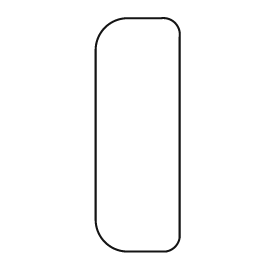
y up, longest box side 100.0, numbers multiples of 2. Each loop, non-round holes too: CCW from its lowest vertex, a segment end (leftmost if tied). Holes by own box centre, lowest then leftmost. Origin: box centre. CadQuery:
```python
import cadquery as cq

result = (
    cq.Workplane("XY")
    .moveTo(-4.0, -50.0)
    .lineTo(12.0, -50.0)
    .threePointArc((16.0, -48.0), (18.0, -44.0))
    .lineTo(18.0, 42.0)
    .threePointArc((16.0, 48.0), (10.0, 50.0))
    .lineTo(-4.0, 50.0)
    .threePointArc((-14.0, 46.0), (-18.0, 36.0))
    .lineTo(-18.0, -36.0)
    .threePointArc((-14.0, -46.0), (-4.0, -50.0))
    .close()
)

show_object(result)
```